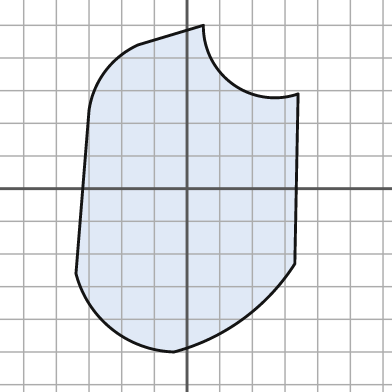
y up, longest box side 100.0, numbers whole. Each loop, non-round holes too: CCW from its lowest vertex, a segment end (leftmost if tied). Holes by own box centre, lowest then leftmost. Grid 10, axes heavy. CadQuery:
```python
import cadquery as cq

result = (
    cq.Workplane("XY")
    .moveTo(-4.0, -50.0)
    .threePointArc((17.0, -40.0), (33.0, -23.0))
    .lineTo(34.0, 29.0)
    .threePointArc((14.0, 32.0), (5.0, 50.0))
    .lineTo(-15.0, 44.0)
    .threePointArc((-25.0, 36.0), (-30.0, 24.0))
    .lineTo(-34.0, -26.0)
    .threePointArc((-23.0, -43.0), (-4.0, -50.0))
    .close()
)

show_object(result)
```